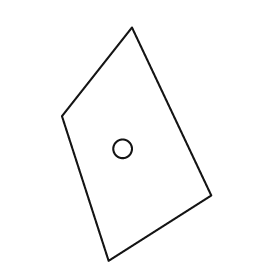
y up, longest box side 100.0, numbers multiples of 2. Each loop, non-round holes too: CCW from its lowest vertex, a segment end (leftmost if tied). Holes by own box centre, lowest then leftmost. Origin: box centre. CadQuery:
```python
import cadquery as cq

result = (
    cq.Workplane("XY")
    .moveTo(-12.0, -50.0)
    .lineTo(32.0, -22.0)
    .lineTo(-2.0, 50.0)
    .lineTo(-32.0, 12.0)
    .close()
    .moveTo(-6.0, -2.0)
    .circle(4.0)
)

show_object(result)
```